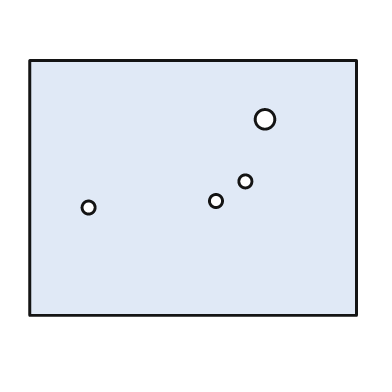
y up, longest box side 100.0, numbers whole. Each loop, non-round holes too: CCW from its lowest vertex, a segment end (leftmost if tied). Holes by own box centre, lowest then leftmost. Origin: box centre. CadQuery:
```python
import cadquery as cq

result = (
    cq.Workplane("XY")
    .moveTo(-50.0, -39.0)
    .lineTo(50.0, -39.0)
    .lineTo(50.0, 39.0)
    .lineTo(-50.0, 39.0)
    .close()
    .moveTo(-32.0, -6.0)
    .circle(2.0)
    .moveTo(7.0, -4.0)
    .circle(2.0)
    .moveTo(16.0, 2.0)
    .circle(2.0)
    .moveTo(22.0, 21.0)
    .circle(3.0)
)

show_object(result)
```